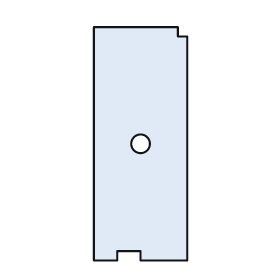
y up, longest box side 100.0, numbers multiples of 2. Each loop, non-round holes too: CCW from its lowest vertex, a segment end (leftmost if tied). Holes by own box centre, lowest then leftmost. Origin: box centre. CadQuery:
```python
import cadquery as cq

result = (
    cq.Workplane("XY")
    .moveTo(-20.0, -50.0)
    .lineTo(-10.0, -50.0)
    .lineTo(-10.0, -46.0)
    .lineTo(0.0, -46.0)
    .lineTo(0.0, -50.0)
    .lineTo(20.0, -50.0)
    .lineTo(20.0, 46.0)
    .lineTo(16.0, 46.0)
    .lineTo(16.0, 50.0)
    .lineTo(-20.0, 50.0)
    .close()
    .moveTo(0.0, 0.0)
    .circle(4.0)
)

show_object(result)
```